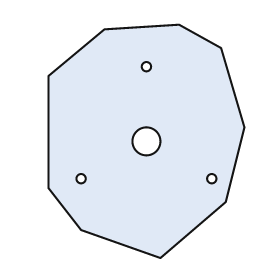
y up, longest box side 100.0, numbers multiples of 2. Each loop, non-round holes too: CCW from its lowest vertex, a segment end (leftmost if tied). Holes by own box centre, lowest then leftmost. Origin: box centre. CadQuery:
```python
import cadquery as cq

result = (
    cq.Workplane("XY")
    .moveTo(6.0, -50.0)
    .lineTo(34.0, -26.0)
    .lineTo(42.0, 6.0)
    .lineTo(32.0, 40.0)
    .lineTo(14.0, 50.0)
    .lineTo(-18.0, 48.0)
    .lineTo(-42.0, 28.0)
    .lineTo(-42.0, -20.0)
    .lineTo(-28.0, -38.0)
    .close()
    .moveTo(-28.0, -16.0)
    .circle(2.0)
    .moveTo(28.0, -16.0)
    .circle(2.0)
    .moveTo(0.0, 0.0)
    .circle(6.0)
    .moveTo(0.0, 32.0)
    .circle(2.0)
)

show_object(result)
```